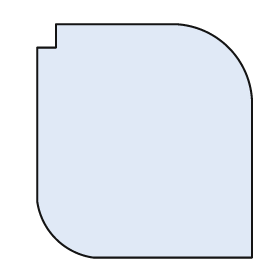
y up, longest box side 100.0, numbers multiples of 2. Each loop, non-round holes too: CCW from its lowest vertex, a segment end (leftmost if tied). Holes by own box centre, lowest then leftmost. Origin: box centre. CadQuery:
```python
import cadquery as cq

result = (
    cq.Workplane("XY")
    .moveTo(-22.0, -50.0)
    .lineTo(46.0, -50.0)
    .lineTo(46.0, 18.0)
    .threePointArc((36.0, 40.0), (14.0, 50.0))
    .lineTo(-38.0, 50.0)
    .lineTo(-38.0, 40.0)
    .lineTo(-46.0, 40.0)
    .lineTo(-46.0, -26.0)
    .threePointArc((-38.0, -42.0), (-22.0, -50.0))
    .close()
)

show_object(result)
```